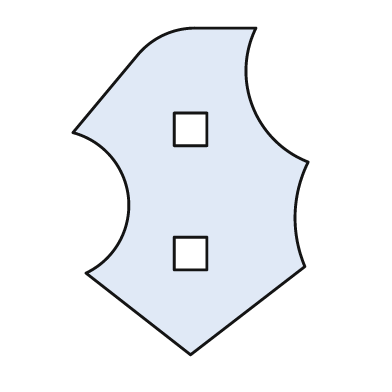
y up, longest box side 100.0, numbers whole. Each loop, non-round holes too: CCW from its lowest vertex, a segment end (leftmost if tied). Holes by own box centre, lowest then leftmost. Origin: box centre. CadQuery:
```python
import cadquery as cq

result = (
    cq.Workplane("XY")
    .moveTo(0.0, -50.0)
    .lineTo(35.0, -23.0)
    .threePointArc((32.0, -7.0), (36.0, 9.0))
    .threePointArc((19.0, 26.0), (20.0, 50.0))
    .lineTo(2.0, 50.0)
    .threePointArc((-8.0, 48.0), (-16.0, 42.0))
    .lineTo(-36.0, 18.0)
    .threePointArc((-19.0, -2.0), (-32.0, -25.0))
    .close()
    .moveTo(-5.0, -24.0)
    .lineTo(5.0, -24.0)
    .lineTo(5.0, -14.0)
    .lineTo(-5.0, -14.0)
    .close()
    .moveTo(-5.0, 14.0)
    .lineTo(5.0, 14.0)
    .lineTo(5.0, 24.0)
    .lineTo(-5.0, 24.0)
    .close()
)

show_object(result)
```